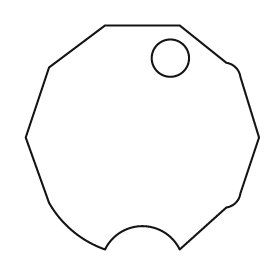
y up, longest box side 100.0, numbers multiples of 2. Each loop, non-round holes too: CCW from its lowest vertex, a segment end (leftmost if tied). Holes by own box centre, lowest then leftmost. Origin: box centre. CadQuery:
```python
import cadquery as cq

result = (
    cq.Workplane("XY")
    .moveTo(-16.0, -48.0)
    .threePointArc((0.0, -38.0), (16.0, -48.0))
    .lineTo(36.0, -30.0)
    .threePointArc((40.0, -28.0), (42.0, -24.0))
    .lineTo(50.0, 0.0)
    .lineTo(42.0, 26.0)
    .threePointArc((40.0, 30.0), (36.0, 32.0))
    .lineTo(16.0, 48.0)
    .lineTo(-16.0, 48.0)
    .lineTo(-40.0, 30.0)
    .lineTo(-50.0, 0.0)
    .lineTo(-40.0, -28.0)
    .threePointArc((-30.0, -40.0), (-16.0, -48.0))
    .close()
    .moveTo(12.0, 34.0)
    .circle(8.0)
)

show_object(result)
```